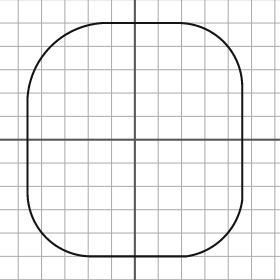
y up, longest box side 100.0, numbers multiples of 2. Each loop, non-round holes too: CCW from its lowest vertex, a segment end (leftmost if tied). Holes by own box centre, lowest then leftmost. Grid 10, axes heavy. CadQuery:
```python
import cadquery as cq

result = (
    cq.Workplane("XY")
    .moveTo(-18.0, -50.0)
    .lineTo(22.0, -50.0)
    .threePointArc((38.0, -42.0), (46.0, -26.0))
    .lineTo(46.0, 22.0)
    .threePointArc((38.0, 42.0), (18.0, 50.0))
    .lineTo(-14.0, 50.0)
    .threePointArc((-36.0, 40.0), (-46.0, 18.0))
    .lineTo(-46.0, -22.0)
    .threePointArc((-38.0, -42.0), (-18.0, -50.0))
    .close()
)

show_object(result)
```